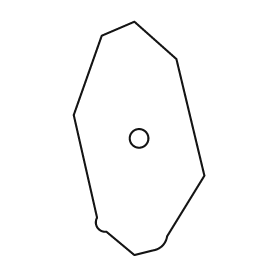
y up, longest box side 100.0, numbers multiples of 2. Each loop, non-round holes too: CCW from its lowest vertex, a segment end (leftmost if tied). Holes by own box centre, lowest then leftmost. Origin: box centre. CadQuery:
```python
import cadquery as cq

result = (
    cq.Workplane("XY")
    .moveTo(-2.0, -50.0)
    .lineTo(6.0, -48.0)
    .threePointArc((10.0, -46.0), (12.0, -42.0))
    .lineTo(28.0, -16.0)
    .lineTo(16.0, 34.0)
    .lineTo(-2.0, 50.0)
    .lineTo(-16.0, 44.0)
    .lineTo(-28.0, 10.0)
    .lineTo(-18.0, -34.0)
    .threePointArc((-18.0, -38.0), (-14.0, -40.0))
    .close()
    .moveTo(0.0, 0.0)
    .circle(4.0)
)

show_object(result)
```